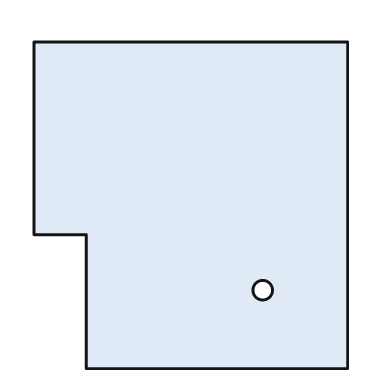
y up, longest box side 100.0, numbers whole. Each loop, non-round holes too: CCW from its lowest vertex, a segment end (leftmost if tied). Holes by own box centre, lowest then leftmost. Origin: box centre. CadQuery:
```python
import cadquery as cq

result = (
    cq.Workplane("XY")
    .moveTo(-32.0, -50.0)
    .lineTo(48.0, -50.0)
    .lineTo(48.0, 50.0)
    .lineTo(-48.0, 50.0)
    .lineTo(-48.0, -9.0)
    .lineTo(-32.0, -9.0)
    .close()
    .moveTo(22.0, -26.0)
    .circle(3.0)
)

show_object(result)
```